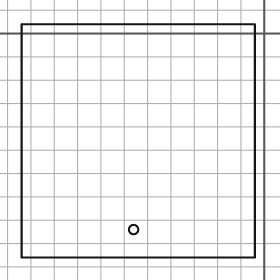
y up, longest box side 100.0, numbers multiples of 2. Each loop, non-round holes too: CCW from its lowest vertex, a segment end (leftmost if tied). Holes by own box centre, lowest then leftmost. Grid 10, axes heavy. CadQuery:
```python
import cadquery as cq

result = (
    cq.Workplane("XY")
    .moveTo(-104.0, -96.0)
    .lineTo(-4.0, -96.0)
    .lineTo(-4.0, 4.0)
    .lineTo(-104.0, 4.0)
    .close()
    .moveTo(-56.0, -84.0)
    .circle(2.0)
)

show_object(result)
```